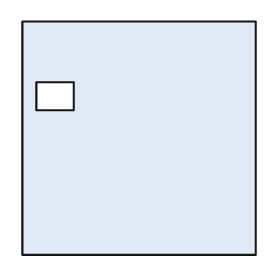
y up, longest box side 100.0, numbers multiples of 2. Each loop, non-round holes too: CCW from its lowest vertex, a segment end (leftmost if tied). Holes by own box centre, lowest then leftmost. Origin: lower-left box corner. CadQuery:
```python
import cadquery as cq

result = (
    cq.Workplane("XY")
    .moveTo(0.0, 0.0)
    .lineTo(100.0, 0.0)
    .lineTo(100.0, 100.0)
    .lineTo(0.0, 100.0)
    .close()
    .moveTo(6.0, 62.0)
    .lineTo(22.0, 62.0)
    .lineTo(22.0, 74.0)
    .lineTo(6.0, 74.0)
    .close()
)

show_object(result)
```